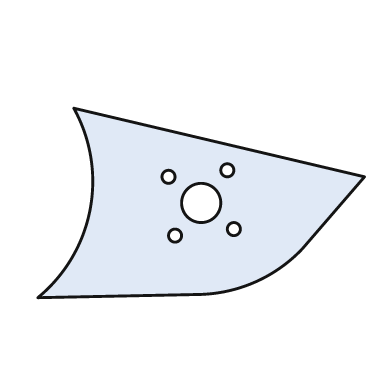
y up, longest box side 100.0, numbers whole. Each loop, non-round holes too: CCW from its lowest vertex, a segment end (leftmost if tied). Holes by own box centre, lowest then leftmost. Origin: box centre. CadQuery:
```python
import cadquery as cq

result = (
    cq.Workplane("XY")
    .moveTo(-50.0, -29.0)
    .lineTo(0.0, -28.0)
    .threePointArc((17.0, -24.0), (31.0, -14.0))
    .lineTo(50.0, 8.0)
    .lineTo(-39.0, 29.0)
    .threePointArc((-34.0, -2.0), (-50.0, -29.0))
    .close()
    .moveTo(-8.0, -10.0)
    .circle(2.0)
    .moveTo(10.0, -8.0)
    .circle(2.0)
    .moveTo(0.0, 0.0)
    .circle(6.0)
    .moveTo(-10.0, 8.0)
    .circle(2.0)
    .moveTo(8.0, 10.0)
    .circle(2.0)
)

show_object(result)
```